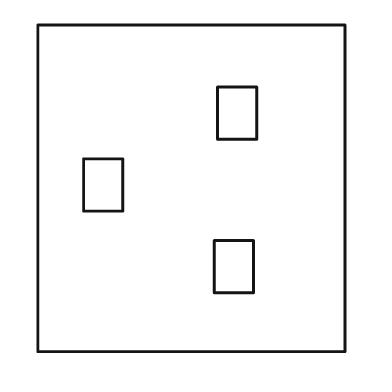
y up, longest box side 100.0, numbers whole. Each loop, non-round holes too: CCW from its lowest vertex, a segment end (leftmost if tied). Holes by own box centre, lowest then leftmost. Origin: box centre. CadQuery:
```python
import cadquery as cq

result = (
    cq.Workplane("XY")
    .moveTo(-47.0, -50.0)
    .lineTo(47.0, -50.0)
    .lineTo(47.0, 50.0)
    .lineTo(-47.0, 50.0)
    .close()
    .moveTo(7.0, -32.0)
    .lineTo(19.0, -32.0)
    .lineTo(19.0, -16.0)
    .lineTo(7.0, -16.0)
    .close()
    .moveTo(-33.0, -7.0)
    .lineTo(-21.0, -7.0)
    .lineTo(-21.0, 9.0)
    .lineTo(-33.0, 9.0)
    .close()
    .moveTo(8.0, 15.0)
    .lineTo(20.0, 15.0)
    .lineTo(20.0, 31.0)
    .lineTo(8.0, 31.0)
    .close()
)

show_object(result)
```